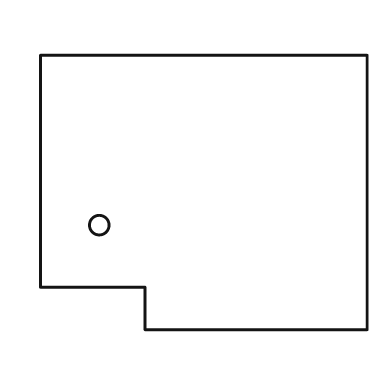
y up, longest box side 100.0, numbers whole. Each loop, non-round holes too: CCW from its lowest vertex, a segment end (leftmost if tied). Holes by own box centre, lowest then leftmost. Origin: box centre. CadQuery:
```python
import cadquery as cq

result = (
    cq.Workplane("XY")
    .moveTo(-18.0, -42.0)
    .lineTo(50.0, -42.0)
    .lineTo(50.0, 42.0)
    .lineTo(-50.0, 42.0)
    .lineTo(-50.0, -29.0)
    .lineTo(-18.0, -29.0)
    .close()
    .moveTo(-32.0, -10.0)
    .circle(3.0)
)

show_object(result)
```